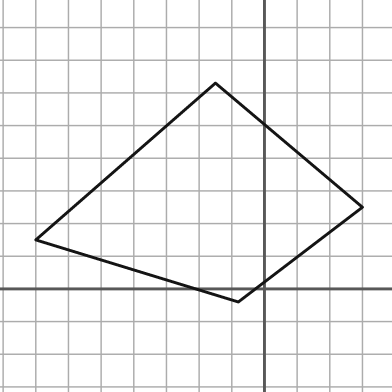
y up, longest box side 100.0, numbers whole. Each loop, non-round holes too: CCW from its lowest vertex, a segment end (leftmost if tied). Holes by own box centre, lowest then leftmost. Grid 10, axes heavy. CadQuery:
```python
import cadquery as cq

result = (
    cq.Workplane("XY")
    .moveTo(-8.0, -4.0)
    .lineTo(30.0, 25.0)
    .lineTo(-15.0, 63.0)
    .lineTo(-70.0, 15.0)
    .close()
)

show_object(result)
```